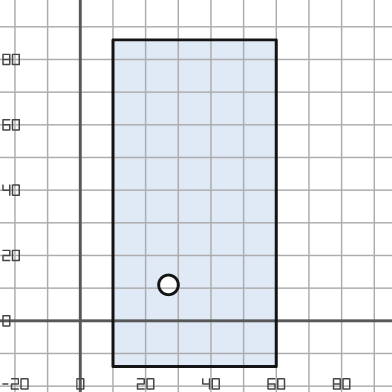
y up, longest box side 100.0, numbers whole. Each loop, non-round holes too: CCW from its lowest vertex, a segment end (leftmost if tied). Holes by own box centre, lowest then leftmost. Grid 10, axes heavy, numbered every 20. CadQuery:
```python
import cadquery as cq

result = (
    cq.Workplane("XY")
    .moveTo(10.0, -14.0)
    .lineTo(60.0, -14.0)
    .lineTo(60.0, 86.0)
    .lineTo(10.0, 86.0)
    .close()
    .moveTo(27.0, 11.0)
    .circle(3.0)
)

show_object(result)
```